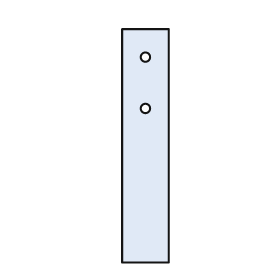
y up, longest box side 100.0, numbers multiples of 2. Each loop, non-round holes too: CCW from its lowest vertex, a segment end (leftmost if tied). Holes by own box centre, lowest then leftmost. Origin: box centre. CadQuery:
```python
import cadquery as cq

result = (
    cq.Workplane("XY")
    .moveTo(-10.0, -50.0)
    .lineTo(10.0, -50.0)
    .lineTo(10.0, 50.0)
    .lineTo(-10.0, 50.0)
    .close()
    .moveTo(0.0, 16.0)
    .circle(2.0)
    .moveTo(0.0, 38.0)
    .circle(2.0)
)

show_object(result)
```